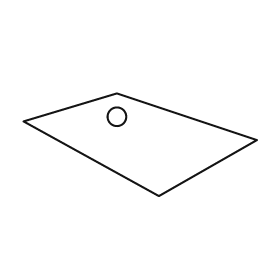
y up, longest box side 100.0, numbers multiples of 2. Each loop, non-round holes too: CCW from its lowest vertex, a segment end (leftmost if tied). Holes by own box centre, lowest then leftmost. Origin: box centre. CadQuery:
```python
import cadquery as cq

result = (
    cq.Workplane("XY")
    .moveTo(8.0, -22.0)
    .lineTo(50.0, 2.0)
    .lineTo(-10.0, 22.0)
    .lineTo(-50.0, 10.0)
    .close()
    .moveTo(-10.0, 12.0)
    .circle(4.0)
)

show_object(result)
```